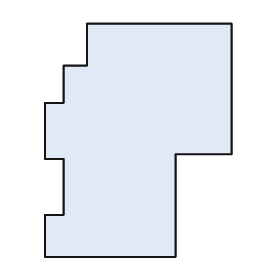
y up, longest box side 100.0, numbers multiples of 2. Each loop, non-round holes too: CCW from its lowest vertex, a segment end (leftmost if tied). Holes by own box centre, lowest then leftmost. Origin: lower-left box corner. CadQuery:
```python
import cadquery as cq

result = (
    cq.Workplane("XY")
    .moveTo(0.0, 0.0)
    .lineTo(56.0, 0.0)
    .lineTo(56.0, 44.0)
    .lineTo(80.0, 44.0)
    .lineTo(80.0, 100.0)
    .lineTo(18.0, 100.0)
    .lineTo(18.0, 82.0)
    .lineTo(8.0, 82.0)
    .lineTo(8.0, 66.0)
    .lineTo(0.0, 66.0)
    .lineTo(0.0, 42.0)
    .lineTo(8.0, 42.0)
    .lineTo(8.0, 18.0)
    .lineTo(0.0, 18.0)
    .close()
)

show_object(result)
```